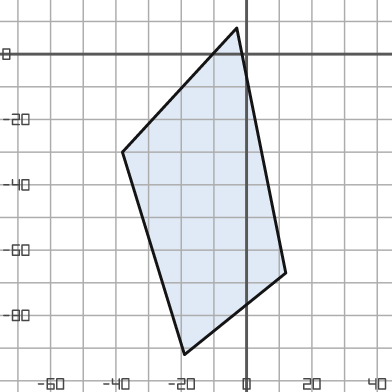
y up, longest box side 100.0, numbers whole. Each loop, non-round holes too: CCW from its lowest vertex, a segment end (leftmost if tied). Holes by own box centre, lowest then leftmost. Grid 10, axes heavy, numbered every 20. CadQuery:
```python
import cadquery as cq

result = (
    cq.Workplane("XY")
    .moveTo(-19.0, -92.0)
    .lineTo(12.0, -67.0)
    .lineTo(-3.0, 8.0)
    .lineTo(-38.0, -30.0)
    .close()
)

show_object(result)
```